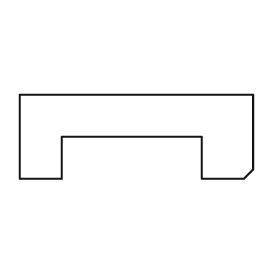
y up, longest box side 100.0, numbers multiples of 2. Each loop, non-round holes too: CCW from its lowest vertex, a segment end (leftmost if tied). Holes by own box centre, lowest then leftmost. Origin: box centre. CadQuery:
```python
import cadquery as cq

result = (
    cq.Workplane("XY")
    .moveTo(-50.0, -18.0)
    .lineTo(-32.0, -18.0)
    .lineTo(-32.0, 0.0)
    .lineTo(28.0, 0.0)
    .lineTo(28.0, -18.0)
    .lineTo(46.0, -18.0)
    .lineTo(50.0, -14.0)
    .lineTo(50.0, 18.0)
    .lineTo(-50.0, 18.0)
    .close()
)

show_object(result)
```